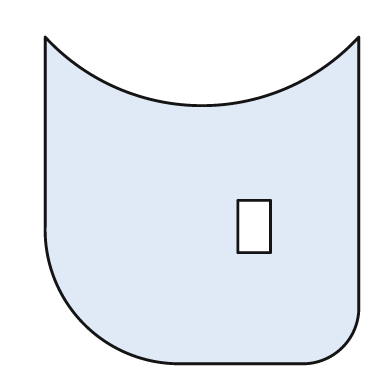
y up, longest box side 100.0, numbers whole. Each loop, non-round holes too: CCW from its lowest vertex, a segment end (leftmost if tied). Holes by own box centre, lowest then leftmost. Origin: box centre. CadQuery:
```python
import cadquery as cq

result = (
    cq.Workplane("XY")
    .moveTo(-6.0, -50.0)
    .lineTo(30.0, -50.0)
    .threePointArc((43.0, -45.0), (48.0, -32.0))
    .lineTo(48.0, 50.0)
    .threePointArc((0.0, 29.0), (-48.0, 50.0))
    .lineTo(-48.0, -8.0)
    .threePointArc((-36.0, -38.0), (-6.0, -50.0))
    .close()
    .moveTo(11.0, -16.0)
    .lineTo(21.0, -16.0)
    .lineTo(21.0, 0.0)
    .lineTo(11.0, 0.0)
    .close()
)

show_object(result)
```